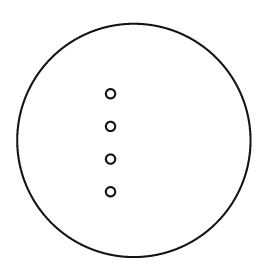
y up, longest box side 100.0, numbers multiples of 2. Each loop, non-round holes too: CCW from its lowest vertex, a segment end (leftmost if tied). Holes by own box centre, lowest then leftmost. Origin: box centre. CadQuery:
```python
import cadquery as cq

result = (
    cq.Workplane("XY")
    .moveTo(0.0, 0.0)
    .circle(50.0)
    .moveTo(-10.0, -22.0)
    .circle(2.0)
    .moveTo(-10.0, -8.0)
    .circle(2.0)
    .moveTo(-10.0, 6.0)
    .circle(2.0)
    .moveTo(-10.0, 20.0)
    .circle(2.0)
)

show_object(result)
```